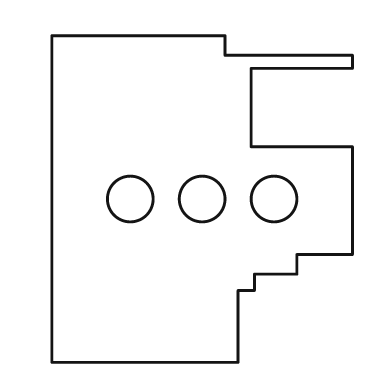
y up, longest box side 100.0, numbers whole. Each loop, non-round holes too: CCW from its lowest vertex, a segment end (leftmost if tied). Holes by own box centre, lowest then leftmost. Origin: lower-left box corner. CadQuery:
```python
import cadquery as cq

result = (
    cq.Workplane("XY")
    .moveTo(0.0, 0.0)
    .lineTo(57.0, 0.0)
    .lineTo(57.0, 22.0)
    .lineTo(62.0, 22.0)
    .lineTo(62.0, 27.0)
    .lineTo(75.0, 27.0)
    .lineTo(75.0, 33.0)
    .lineTo(92.0, 33.0)
    .lineTo(92.0, 66.0)
    .lineTo(61.0, 66.0)
    .lineTo(61.0, 90.0)
    .lineTo(92.0, 90.0)
    .lineTo(92.0, 94.0)
    .lineTo(53.0, 94.0)
    .lineTo(53.0, 100.0)
    .lineTo(0.0, 100.0)
    .close()
    .moveTo(24.0, 50.0)
    .circle(7.0)
    .moveTo(46.0, 50.0)
    .circle(7.0)
    .moveTo(68.0, 50.0)
    .circle(7.0)
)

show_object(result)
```